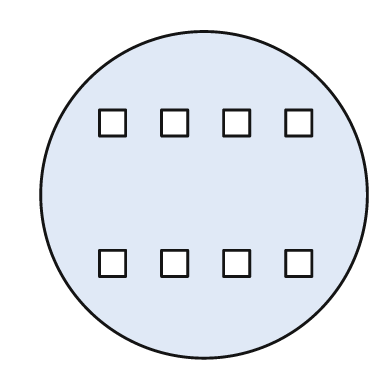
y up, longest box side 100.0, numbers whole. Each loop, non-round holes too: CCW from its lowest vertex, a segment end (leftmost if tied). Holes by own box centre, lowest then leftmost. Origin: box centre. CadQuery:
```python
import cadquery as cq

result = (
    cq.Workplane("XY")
    .moveTo(0.0, 0.0)
    .circle(50.0)
    .moveTo(-32.0, -25.0)
    .lineTo(-24.0, -25.0)
    .lineTo(-24.0, -17.0)
    .lineTo(-32.0, -17.0)
    .close()
    .moveTo(-13.0, -25.0)
    .lineTo(-5.0, -25.0)
    .lineTo(-5.0, -17.0)
    .lineTo(-13.0, -17.0)
    .close()
    .moveTo(6.0, -25.0)
    .lineTo(14.0, -25.0)
    .lineTo(14.0, -17.0)
    .lineTo(6.0, -17.0)
    .close()
    .moveTo(25.0, -25.0)
    .lineTo(33.0, -25.0)
    .lineTo(33.0, -17.0)
    .lineTo(25.0, -17.0)
    .close()
    .moveTo(-32.0, 18.0)
    .lineTo(-24.0, 18.0)
    .lineTo(-24.0, 26.0)
    .lineTo(-32.0, 26.0)
    .close()
    .moveTo(-13.0, 18.0)
    .lineTo(-5.0, 18.0)
    .lineTo(-5.0, 26.0)
    .lineTo(-13.0, 26.0)
    .close()
    .moveTo(6.0, 18.0)
    .lineTo(14.0, 18.0)
    .lineTo(14.0, 26.0)
    .lineTo(6.0, 26.0)
    .close()
    .moveTo(25.0, 18.0)
    .lineTo(33.0, 18.0)
    .lineTo(33.0, 26.0)
    .lineTo(25.0, 26.0)
    .close()
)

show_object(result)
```